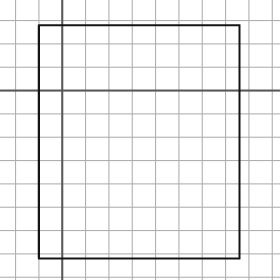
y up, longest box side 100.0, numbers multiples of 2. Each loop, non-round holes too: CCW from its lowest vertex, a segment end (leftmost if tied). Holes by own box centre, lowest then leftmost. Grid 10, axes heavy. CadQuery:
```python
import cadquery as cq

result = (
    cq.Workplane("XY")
    .moveTo(-10.0, -72.0)
    .lineTo(76.0, -72.0)
    .lineTo(76.0, 28.0)
    .lineTo(-10.0, 28.0)
    .close()
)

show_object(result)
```